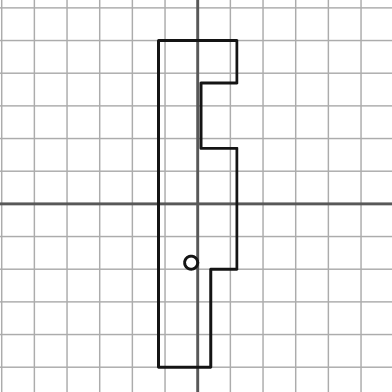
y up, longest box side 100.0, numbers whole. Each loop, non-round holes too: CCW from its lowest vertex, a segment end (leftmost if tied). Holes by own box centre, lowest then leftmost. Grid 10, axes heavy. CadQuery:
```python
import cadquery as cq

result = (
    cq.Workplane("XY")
    .moveTo(-12.0, -50.0)
    .lineTo(4.0, -50.0)
    .lineTo(4.0, -20.0)
    .lineTo(12.0, -20.0)
    .lineTo(12.0, 17.0)
    .lineTo(1.0, 17.0)
    .lineTo(1.0, 37.0)
    .lineTo(12.0, 37.0)
    .lineTo(12.0, 50.0)
    .lineTo(-12.0, 50.0)
    .close()
    .moveTo(-2.0, -18.0)
    .circle(2.0)
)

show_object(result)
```